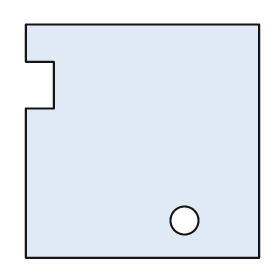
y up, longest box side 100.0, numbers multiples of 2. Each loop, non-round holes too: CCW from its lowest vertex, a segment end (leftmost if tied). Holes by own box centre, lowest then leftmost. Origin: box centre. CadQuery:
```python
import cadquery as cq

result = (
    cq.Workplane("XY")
    .moveTo(-50.0, -50.0)
    .lineTo(50.0, -50.0)
    .lineTo(50.0, 50.0)
    .lineTo(-50.0, 50.0)
    .lineTo(-50.0, 34.0)
    .lineTo(-38.0, 34.0)
    .lineTo(-38.0, 14.0)
    .lineTo(-50.0, 14.0)
    .close()
    .moveTo(18.0, -34.0)
    .circle(6.0)
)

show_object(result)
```